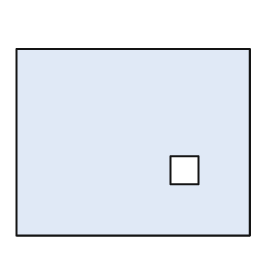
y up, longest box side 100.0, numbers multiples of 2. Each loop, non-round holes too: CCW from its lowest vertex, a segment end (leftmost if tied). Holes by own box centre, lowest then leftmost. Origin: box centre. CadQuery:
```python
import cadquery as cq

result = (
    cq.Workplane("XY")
    .moveTo(-50.0, -40.0)
    .lineTo(50.0, -40.0)
    .lineTo(50.0, 40.0)
    .lineTo(-50.0, 40.0)
    .close()
    .moveTo(16.0, -18.0)
    .lineTo(28.0, -18.0)
    .lineTo(28.0, -6.0)
    .lineTo(16.0, -6.0)
    .close()
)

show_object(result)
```